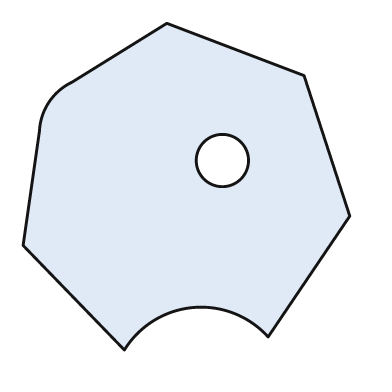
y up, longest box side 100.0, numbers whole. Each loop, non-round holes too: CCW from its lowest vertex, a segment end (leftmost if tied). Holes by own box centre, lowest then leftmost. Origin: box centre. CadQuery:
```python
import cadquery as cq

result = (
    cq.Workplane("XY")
    .moveTo(-19.0, -50.0)
    .threePointArc((2.0, -37.0), (25.0, -46.0))
    .lineTo(50.0, -9.0)
    .lineTo(36.0, 34.0)
    .lineTo(-6.0, 50.0)
    .lineTo(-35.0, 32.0)
    .threePointArc((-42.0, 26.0), (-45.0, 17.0))
    .lineTo(-50.0, -18.0)
    .close()
    .moveTo(11.0, 8.0)
    .circle(8.0)
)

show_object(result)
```